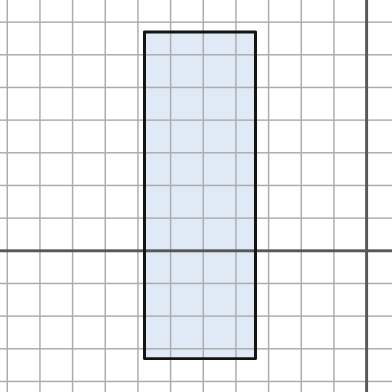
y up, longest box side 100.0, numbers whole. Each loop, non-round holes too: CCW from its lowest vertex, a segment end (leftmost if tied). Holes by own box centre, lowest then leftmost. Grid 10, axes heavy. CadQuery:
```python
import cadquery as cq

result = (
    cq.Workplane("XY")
    .moveTo(-68.0, -33.0)
    .lineTo(-34.0, -33.0)
    .lineTo(-34.0, 67.0)
    .lineTo(-68.0, 67.0)
    .close()
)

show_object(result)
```